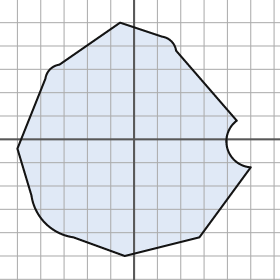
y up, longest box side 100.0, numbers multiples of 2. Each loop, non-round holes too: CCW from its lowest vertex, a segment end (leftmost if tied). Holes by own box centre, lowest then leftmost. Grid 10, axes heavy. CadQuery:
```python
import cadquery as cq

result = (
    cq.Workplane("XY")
    .moveTo(-4.0, -50.0)
    .lineTo(28.0, -42.0)
    .lineTo(50.0, -12.0)
    .threePointArc((40.0, -4.0), (44.0, 8.0))
    .lineTo(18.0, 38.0)
    .threePointArc((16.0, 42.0), (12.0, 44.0))
    .lineTo(-6.0, 50.0)
    .lineTo(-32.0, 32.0)
    .threePointArc((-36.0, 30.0), (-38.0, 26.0))
    .lineTo(-50.0, -4.0)
    .lineTo(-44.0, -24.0)
    .threePointArc((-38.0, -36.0), (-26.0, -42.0))
    .close()
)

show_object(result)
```